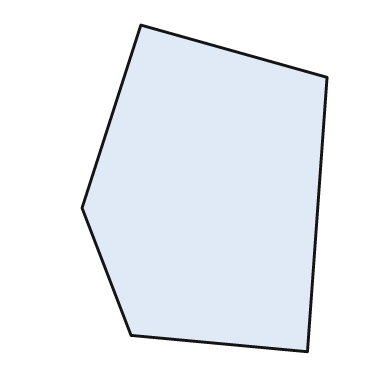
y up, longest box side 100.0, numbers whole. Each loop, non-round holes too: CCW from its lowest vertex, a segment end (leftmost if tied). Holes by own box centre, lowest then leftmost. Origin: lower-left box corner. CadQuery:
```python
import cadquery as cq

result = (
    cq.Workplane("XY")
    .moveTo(69.0, 0.0)
    .lineTo(75.0, 84.0)
    .lineTo(18.0, 100.0)
    .lineTo(0.0, 44.0)
    .lineTo(15.0, 5.0)
    .close()
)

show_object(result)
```